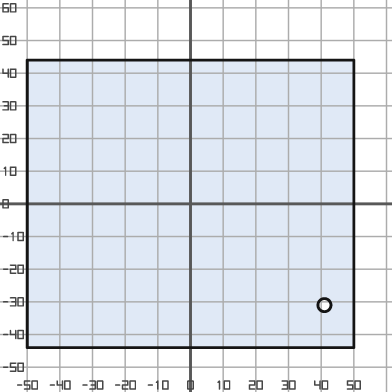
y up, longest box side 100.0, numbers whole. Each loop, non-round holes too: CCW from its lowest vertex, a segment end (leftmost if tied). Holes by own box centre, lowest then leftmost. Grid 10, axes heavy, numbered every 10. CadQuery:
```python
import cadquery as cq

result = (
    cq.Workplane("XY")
    .moveTo(-50.0, -44.0)
    .lineTo(50.0, -44.0)
    .lineTo(50.0, 44.0)
    .lineTo(-50.0, 44.0)
    .close()
    .moveTo(41.0, -31.0)
    .circle(2.0)
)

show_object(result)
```